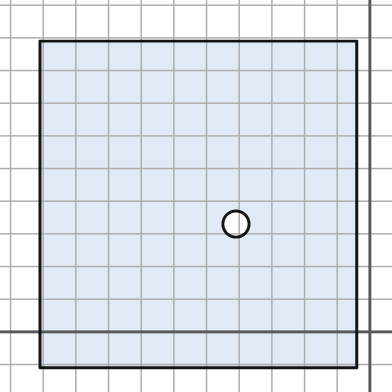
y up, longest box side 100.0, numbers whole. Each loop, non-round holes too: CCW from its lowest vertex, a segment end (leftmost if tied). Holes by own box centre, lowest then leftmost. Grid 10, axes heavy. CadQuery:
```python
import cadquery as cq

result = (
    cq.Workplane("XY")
    .moveTo(-101.0, -11.0)
    .lineTo(-4.0, -11.0)
    .lineTo(-4.0, 89.0)
    .lineTo(-101.0, 89.0)
    .close()
    .moveTo(-41.0, 33.0)
    .circle(4.0)
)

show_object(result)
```